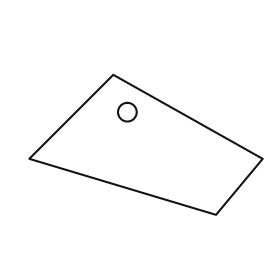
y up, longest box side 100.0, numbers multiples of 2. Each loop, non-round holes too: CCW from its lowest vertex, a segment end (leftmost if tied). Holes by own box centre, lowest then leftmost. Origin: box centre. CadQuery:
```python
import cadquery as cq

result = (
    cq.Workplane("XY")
    .moveTo(30.0, -30.0)
    .lineTo(50.0, -6.0)
    .lineTo(-14.0, 30.0)
    .lineTo(-50.0, -6.0)
    .close()
    .moveTo(-8.0, 14.0)
    .circle(4.0)
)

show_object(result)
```